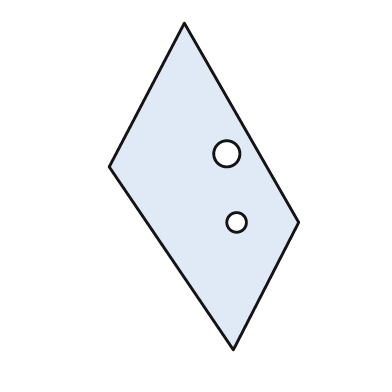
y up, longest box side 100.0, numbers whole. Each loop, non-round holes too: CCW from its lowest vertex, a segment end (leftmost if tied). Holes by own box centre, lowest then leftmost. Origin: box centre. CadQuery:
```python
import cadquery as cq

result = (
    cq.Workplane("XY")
    .moveTo(9.0, -50.0)
    .lineTo(29.0, -11.0)
    .lineTo(-6.0, 50.0)
    .lineTo(-29.0, 6.0)
    .close()
    .moveTo(10.0, -11.0)
    .circle(3.0)
    .moveTo(7.0, 10.0)
    .circle(4.0)
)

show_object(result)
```